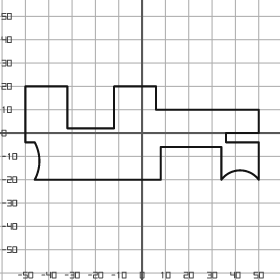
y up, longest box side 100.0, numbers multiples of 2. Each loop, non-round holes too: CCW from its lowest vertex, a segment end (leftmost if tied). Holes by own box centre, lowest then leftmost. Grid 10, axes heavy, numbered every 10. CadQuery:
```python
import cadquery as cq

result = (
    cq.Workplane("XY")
    .moveTo(-46.0, -20.0)
    .lineTo(8.0, -20.0)
    .lineTo(8.0, -6.0)
    .lineTo(34.0, -6.0)
    .lineTo(34.0, -20.0)
    .threePointArc((42.0, -16.0), (50.0, -20.0))
    .lineTo(50.0, -4.0)
    .lineTo(36.0, -4.0)
    .lineTo(36.0, 0.0)
    .lineTo(50.0, 0.0)
    .lineTo(50.0, 10.0)
    .lineTo(6.0, 10.0)
    .lineTo(6.0, 20.0)
    .lineTo(-12.0, 20.0)
    .lineTo(-12.0, 2.0)
    .lineTo(-32.0, 2.0)
    .lineTo(-32.0, 20.0)
    .lineTo(-50.0, 20.0)
    .lineTo(-50.0, -4.0)
    .lineTo(-46.0, -4.0)
    .threePointArc((-44.0, -12.0), (-46.0, -20.0))
    .close()
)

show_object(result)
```